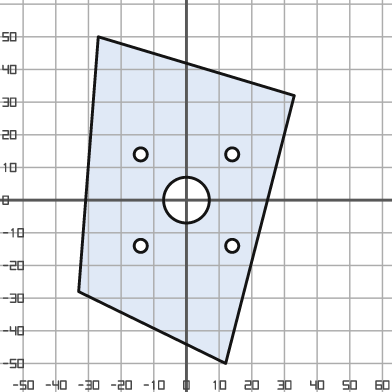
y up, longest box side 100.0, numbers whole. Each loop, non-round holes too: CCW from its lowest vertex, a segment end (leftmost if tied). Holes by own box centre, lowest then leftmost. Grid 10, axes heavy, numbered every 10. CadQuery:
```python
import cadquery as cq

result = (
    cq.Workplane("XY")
    .moveTo(12.0, -50.0)
    .lineTo(33.0, 32.0)
    .lineTo(-27.0, 50.0)
    .lineTo(-33.0, -28.0)
    .close()
    .moveTo(-14.0, -14.0)
    .circle(2.0)
    .moveTo(14.0, -14.0)
    .circle(2.0)
    .moveTo(0.0, 0.0)
    .circle(7.0)
    .moveTo(-14.0, 14.0)
    .circle(2.0)
    .moveTo(14.0, 14.0)
    .circle(2.0)
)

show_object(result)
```